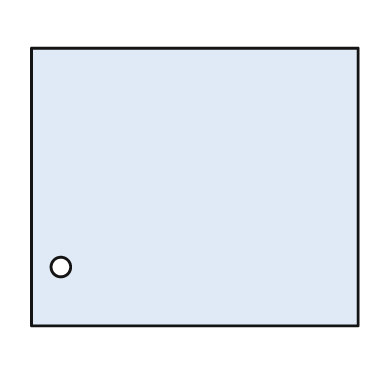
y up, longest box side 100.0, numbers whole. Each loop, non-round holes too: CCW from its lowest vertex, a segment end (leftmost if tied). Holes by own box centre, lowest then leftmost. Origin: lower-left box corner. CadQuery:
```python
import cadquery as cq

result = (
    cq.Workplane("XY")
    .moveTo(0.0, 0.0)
    .lineTo(100.0, 0.0)
    .lineTo(100.0, 85.0)
    .lineTo(0.0, 85.0)
    .close()
    .moveTo(9.0, 18.0)
    .circle(3.0)
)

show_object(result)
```